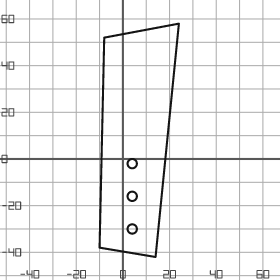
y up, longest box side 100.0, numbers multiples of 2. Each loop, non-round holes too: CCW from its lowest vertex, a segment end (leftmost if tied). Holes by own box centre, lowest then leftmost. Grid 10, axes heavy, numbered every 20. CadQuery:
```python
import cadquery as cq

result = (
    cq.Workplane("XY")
    .moveTo(14.0, -42.0)
    .lineTo(24.0, 58.0)
    .lineTo(-8.0, 52.0)
    .lineTo(-10.0, -38.0)
    .close()
    .moveTo(4.0, -30.0)
    .circle(2.0)
    .moveTo(4.0, -16.0)
    .circle(2.0)
    .moveTo(4.0, -2.0)
    .circle(2.0)
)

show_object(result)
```